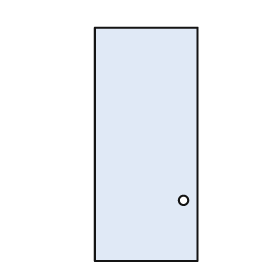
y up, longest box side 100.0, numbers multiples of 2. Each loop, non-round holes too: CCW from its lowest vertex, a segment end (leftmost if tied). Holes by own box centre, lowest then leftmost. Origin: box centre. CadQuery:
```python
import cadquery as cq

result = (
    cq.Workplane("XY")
    .moveTo(-22.0, -50.0)
    .lineTo(22.0, -50.0)
    .lineTo(22.0, 50.0)
    .lineTo(-22.0, 50.0)
    .close()
    .moveTo(16.0, -24.0)
    .circle(2.0)
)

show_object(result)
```